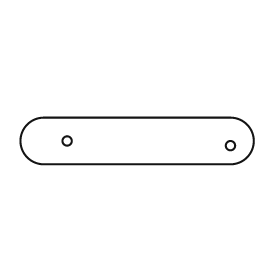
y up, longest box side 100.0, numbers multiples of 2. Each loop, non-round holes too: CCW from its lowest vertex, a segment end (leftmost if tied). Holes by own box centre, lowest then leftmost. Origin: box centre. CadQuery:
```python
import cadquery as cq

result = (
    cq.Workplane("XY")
    .moveTo(-40.0, -10.0)
    .lineTo(40.0, -10.0)
    .threePointArc((50.0, 0.0), (40.0, 10.0))
    .lineTo(-40.0, 10.0)
    .threePointArc((-50.0, 0.0), (-40.0, -10.0))
    .close()
    .moveTo(40.0, -2.0)
    .circle(2.0)
    .moveTo(-30.0, 0.0)
    .circle(2.0)
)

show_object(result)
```